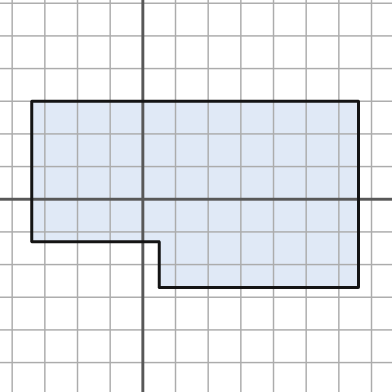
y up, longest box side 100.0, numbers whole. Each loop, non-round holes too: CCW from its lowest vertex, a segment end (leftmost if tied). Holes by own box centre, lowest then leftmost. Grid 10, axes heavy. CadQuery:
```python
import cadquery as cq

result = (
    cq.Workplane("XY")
    .moveTo(5.0, -27.0)
    .lineTo(66.0, -27.0)
    .lineTo(66.0, 30.0)
    .lineTo(-34.0, 30.0)
    .lineTo(-34.0, -13.0)
    .lineTo(5.0, -13.0)
    .close()
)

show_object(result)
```